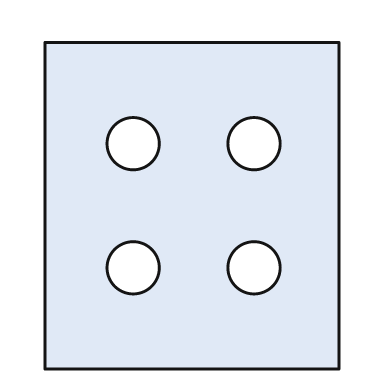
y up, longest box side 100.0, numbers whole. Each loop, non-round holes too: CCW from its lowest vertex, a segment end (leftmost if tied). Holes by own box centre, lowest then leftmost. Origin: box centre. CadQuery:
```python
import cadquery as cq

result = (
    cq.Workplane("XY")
    .moveTo(-45.0, -50.0)
    .lineTo(45.0, -50.0)
    .lineTo(45.0, 50.0)
    .lineTo(-45.0, 50.0)
    .close()
    .moveTo(-18.0, -19.0)
    .circle(8.0)
    .moveTo(19.0, -19.0)
    .circle(8.0)
    .moveTo(-18.0, 19.0)
    .circle(8.0)
    .moveTo(19.0, 19.0)
    .circle(8.0)
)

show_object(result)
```